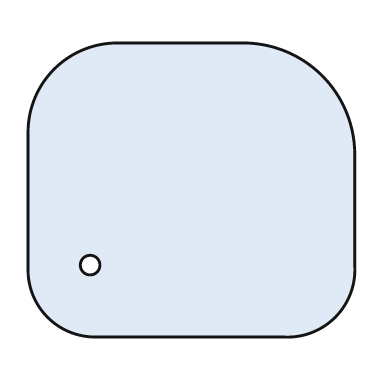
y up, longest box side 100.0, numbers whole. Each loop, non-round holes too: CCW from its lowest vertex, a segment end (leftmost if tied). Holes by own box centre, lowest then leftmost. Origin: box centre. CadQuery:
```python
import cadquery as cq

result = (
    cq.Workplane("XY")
    .moveTo(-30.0, -45.0)
    .lineTo(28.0, -45.0)
    .threePointArc((44.0, -39.0), (50.0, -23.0))
    .lineTo(50.0, 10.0)
    .threePointArc((40.0, 35.0), (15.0, 45.0))
    .lineTo(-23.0, 45.0)
    .threePointArc((-42.0, 37.0), (-50.0, 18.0))
    .lineTo(-50.0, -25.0)
    .threePointArc((-44.0, -39.0), (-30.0, -45.0))
    .close()
    .moveTo(-31.0, -23.0)
    .circle(3.0)
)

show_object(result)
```